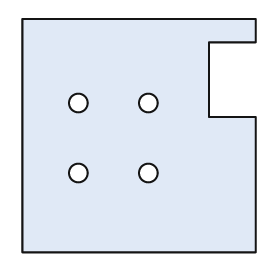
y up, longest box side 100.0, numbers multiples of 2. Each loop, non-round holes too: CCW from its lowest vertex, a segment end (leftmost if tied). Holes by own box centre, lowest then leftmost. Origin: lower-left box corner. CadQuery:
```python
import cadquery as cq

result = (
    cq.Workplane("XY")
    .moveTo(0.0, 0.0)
    .lineTo(100.0, 0.0)
    .lineTo(100.0, 58.0)
    .lineTo(80.0, 58.0)
    .lineTo(80.0, 90.0)
    .lineTo(100.0, 90.0)
    .lineTo(100.0, 100.0)
    .lineTo(0.0, 100.0)
    .close()
    .moveTo(24.0, 34.0)
    .circle(4.0)
    .moveTo(54.0, 34.0)
    .circle(4.0)
    .moveTo(24.0, 64.0)
    .circle(4.0)
    .moveTo(54.0, 64.0)
    .circle(4.0)
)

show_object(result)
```